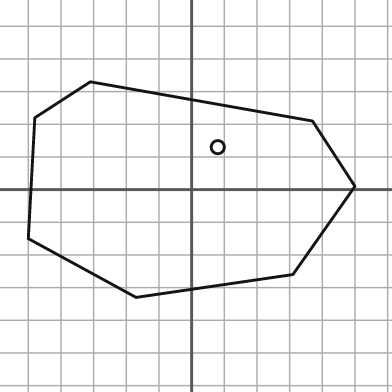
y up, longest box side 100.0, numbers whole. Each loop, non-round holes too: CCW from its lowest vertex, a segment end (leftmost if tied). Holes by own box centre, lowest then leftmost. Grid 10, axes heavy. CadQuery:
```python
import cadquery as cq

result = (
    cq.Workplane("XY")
    .moveTo(-17.0, -33.0)
    .lineTo(31.0, -26.0)
    .lineTo(50.0, 1.0)
    .lineTo(37.0, 21.0)
    .lineTo(-31.0, 33.0)
    .lineTo(-48.0, 22.0)
    .lineTo(-50.0, -15.0)
    .close()
    .moveTo(8.0, 13.0)
    .circle(2.0)
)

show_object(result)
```